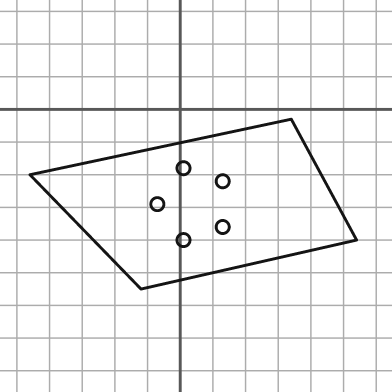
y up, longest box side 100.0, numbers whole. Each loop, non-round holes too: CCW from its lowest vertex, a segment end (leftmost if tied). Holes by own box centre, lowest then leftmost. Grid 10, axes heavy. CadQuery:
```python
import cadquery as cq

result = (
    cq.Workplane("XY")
    .moveTo(-12.0, -55.0)
    .lineTo(54.0, -40.0)
    .lineTo(34.0, -3.0)
    .lineTo(-46.0, -20.0)
    .close()
    .moveTo(1.0, -40.0)
    .circle(2.0)
    .moveTo(13.0, -36.0)
    .circle(2.0)
    .moveTo(-7.0, -29.0)
    .circle(2.0)
    .moveTo(13.0, -22.0)
    .circle(2.0)
    .moveTo(1.0, -18.0)
    .circle(2.0)
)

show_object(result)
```